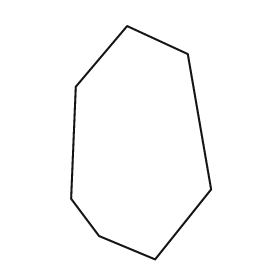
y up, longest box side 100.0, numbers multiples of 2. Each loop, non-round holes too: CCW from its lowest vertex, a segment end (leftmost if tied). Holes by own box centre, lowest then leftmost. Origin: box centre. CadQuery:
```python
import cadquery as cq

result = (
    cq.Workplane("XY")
    .moveTo(6.0, -50.0)
    .lineTo(30.0, -20.0)
    .lineTo(20.0, 38.0)
    .lineTo(-6.0, 50.0)
    .lineTo(-28.0, 24.0)
    .lineTo(-30.0, -24.0)
    .lineTo(-18.0, -40.0)
    .close()
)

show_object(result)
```